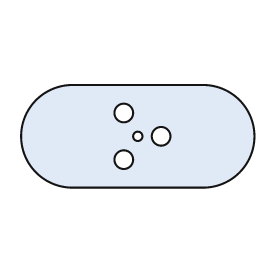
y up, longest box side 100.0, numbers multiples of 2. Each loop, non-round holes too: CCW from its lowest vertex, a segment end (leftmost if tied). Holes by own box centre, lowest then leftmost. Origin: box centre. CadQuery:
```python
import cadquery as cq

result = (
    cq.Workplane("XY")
    .moveTo(-28.0, -22.0)
    .lineTo(28.0, -22.0)
    .threePointArc((50.0, 0.0), (28.0, 22.0))
    .lineTo(-28.0, 22.0)
    .threePointArc((-50.0, 0.0), (-28.0, -22.0))
    .close()
    .moveTo(-6.0, -10.0)
    .circle(4.0)
    .moveTo(0.0, 0.0)
    .circle(2.0)
    .moveTo(10.0, 0.0)
    .circle(4.0)
    .moveTo(-6.0, 10.0)
    .circle(4.0)
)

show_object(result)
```